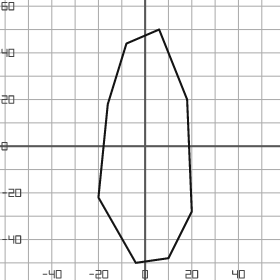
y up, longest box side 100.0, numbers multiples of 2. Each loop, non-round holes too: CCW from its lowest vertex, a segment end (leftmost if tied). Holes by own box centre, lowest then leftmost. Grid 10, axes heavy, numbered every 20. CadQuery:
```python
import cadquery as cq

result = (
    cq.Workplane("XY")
    .moveTo(-4.0, -50.0)
    .lineTo(10.0, -48.0)
    .lineTo(20.0, -28.0)
    .lineTo(18.0, 20.0)
    .lineTo(6.0, 50.0)
    .lineTo(-8.0, 44.0)
    .lineTo(-16.0, 18.0)
    .lineTo(-20.0, -22.0)
    .close()
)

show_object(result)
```